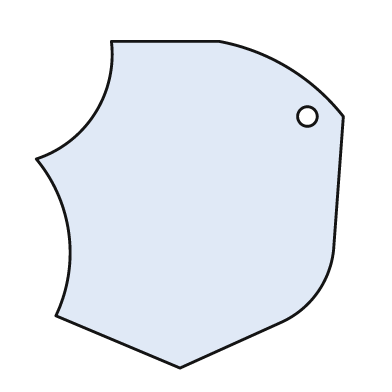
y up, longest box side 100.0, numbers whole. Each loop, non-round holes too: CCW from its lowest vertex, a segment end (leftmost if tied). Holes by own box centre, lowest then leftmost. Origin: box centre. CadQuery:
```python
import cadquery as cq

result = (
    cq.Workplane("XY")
    .moveTo(-3.0, -50.0)
    .lineTo(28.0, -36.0)
    .threePointArc((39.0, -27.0), (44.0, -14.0))
    .lineTo(47.0, 27.0)
    .threePointArc((30.0, 42.0), (9.0, 50.0))
    .lineTo(-24.0, 50.0)
    .threePointArc((-29.0, 28.0), (-47.0, 14.0))
    .threePointArc((-37.0, -9.0), (-41.0, -34.0))
    .close()
    .moveTo(36.0, 27.0)
    .circle(3.0)
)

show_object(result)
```